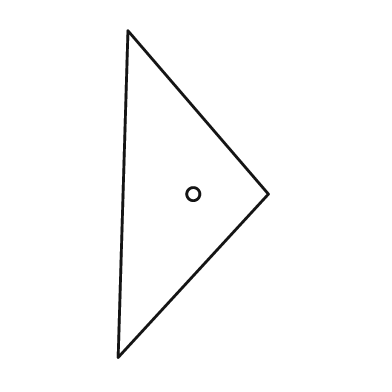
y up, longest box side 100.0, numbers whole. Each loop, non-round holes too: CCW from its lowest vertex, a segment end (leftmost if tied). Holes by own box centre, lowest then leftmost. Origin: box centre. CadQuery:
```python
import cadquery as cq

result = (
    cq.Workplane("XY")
    .moveTo(-23.0, -50.0)
    .lineTo(23.0, 0.0)
    .lineTo(-20.0, 50.0)
    .close()
    .moveTo(0.0, 0.0)
    .circle(2.0)
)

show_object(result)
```